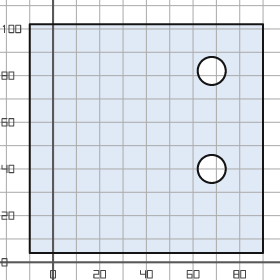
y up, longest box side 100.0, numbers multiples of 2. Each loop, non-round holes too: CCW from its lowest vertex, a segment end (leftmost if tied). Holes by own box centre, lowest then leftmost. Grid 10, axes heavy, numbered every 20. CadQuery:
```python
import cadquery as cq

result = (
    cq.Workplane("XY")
    .moveTo(-10.0, 4.0)
    .lineTo(90.0, 4.0)
    .lineTo(90.0, 102.0)
    .lineTo(-10.0, 102.0)
    .close()
    .moveTo(68.0, 40.0)
    .circle(6.0)
    .moveTo(68.0, 82.0)
    .circle(6.0)
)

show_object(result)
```